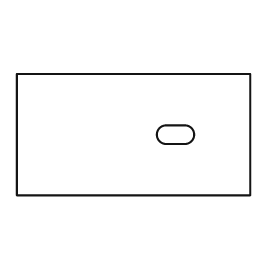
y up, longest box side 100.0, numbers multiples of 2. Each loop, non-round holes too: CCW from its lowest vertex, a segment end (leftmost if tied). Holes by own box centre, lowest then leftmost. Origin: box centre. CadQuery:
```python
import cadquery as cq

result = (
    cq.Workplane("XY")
    .moveTo(-50.0, -26.0)
    .lineTo(50.0, -26.0)
    .lineTo(50.0, 26.0)
    .lineTo(-50.0, 26.0)
    .close()
    .moveTo(14.0, -4.0)
    .lineTo(22.0, -4.0)
    .threePointArc((26.0, 0.0), (22.0, 4.0))
    .lineTo(14.0, 4.0)
    .threePointArc((10.0, 0.0), (14.0, -4.0))
    .close()
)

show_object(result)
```